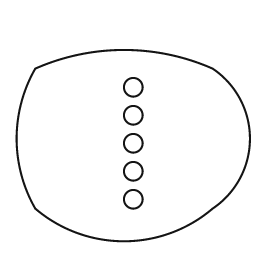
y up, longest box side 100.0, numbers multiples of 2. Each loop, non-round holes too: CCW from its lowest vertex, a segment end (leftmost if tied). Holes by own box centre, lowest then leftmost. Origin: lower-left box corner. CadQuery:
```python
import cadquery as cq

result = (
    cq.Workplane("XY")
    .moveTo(8.0, 14.0)
    .threePointArc((46.0, 0.0), (84.0, 14.0))
    .threePointArc((100.0, 44.0), (84.0, 74.0))
    .threePointArc((46.0, 82.0), (8.0, 74.0))
    .threePointArc((0.0, 44.0), (8.0, 14.0))
    .close()
    .moveTo(50.0, 18.0)
    .circle(4.0)
    .moveTo(50.0, 30.0)
    .circle(4.0)
    .moveTo(50.0, 42.0)
    .circle(4.0)
    .moveTo(50.0, 54.0)
    .circle(4.0)
    .moveTo(50.0, 66.0)
    .circle(4.0)
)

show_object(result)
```